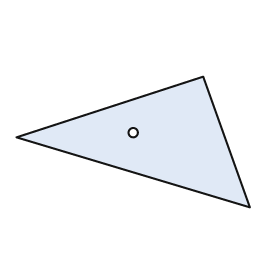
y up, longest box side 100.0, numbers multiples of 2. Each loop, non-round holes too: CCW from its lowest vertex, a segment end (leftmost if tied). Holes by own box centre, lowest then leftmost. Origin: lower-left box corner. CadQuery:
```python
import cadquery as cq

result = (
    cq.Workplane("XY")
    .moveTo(100.0, 0.0)
    .lineTo(80.0, 56.0)
    .lineTo(0.0, 30.0)
    .close()
    .moveTo(50.0, 32.0)
    .circle(2.0)
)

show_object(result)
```